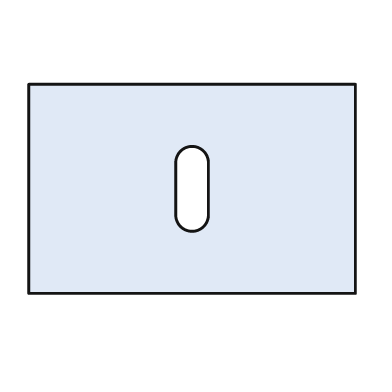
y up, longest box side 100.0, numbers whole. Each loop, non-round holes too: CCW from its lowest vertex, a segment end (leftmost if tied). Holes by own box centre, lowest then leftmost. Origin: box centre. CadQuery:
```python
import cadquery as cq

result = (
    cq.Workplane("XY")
    .moveTo(-50.0, -32.0)
    .lineTo(50.0, -32.0)
    .lineTo(50.0, 32.0)
    .lineTo(-50.0, 32.0)
    .close()
    .moveTo(-5.0, -8.0)
    .threePointArc((0.0, -13.0), (5.0, -8.0))
    .lineTo(5.0, 8.0)
    .threePointArc((0.0, 13.0), (-5.0, 8.0))
    .close()
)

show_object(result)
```